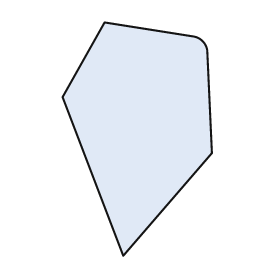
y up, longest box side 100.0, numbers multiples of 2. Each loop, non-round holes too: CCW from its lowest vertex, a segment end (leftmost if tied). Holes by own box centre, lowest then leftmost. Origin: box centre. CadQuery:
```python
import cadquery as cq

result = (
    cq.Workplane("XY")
    .moveTo(-6.0, -50.0)
    .lineTo(32.0, -6.0)
    .lineTo(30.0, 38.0)
    .threePointArc((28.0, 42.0), (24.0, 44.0))
    .lineTo(-14.0, 50.0)
    .lineTo(-32.0, 18.0)
    .close()
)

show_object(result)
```